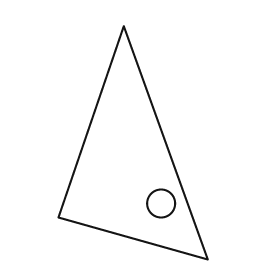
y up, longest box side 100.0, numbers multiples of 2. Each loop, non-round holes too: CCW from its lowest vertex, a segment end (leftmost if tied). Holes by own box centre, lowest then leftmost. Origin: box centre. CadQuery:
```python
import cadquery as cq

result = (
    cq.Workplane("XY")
    .moveTo(32.0, -50.0)
    .lineTo(-4.0, 50.0)
    .lineTo(-32.0, -32.0)
    .close()
    .moveTo(12.0, -26.0)
    .circle(6.0)
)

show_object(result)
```